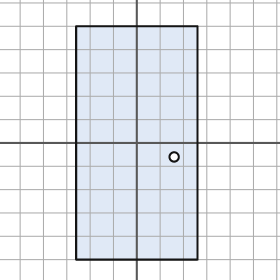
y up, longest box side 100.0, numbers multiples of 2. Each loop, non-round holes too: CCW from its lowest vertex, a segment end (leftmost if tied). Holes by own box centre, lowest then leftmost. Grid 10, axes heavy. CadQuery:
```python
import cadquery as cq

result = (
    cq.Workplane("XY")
    .moveTo(-26.0, -50.0)
    .lineTo(26.0, -50.0)
    .lineTo(26.0, 50.0)
    .lineTo(-26.0, 50.0)
    .close()
    .moveTo(16.0, -6.0)
    .circle(2.0)
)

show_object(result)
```